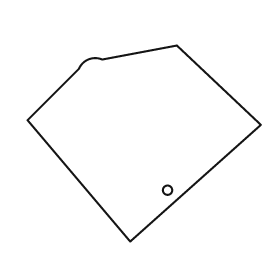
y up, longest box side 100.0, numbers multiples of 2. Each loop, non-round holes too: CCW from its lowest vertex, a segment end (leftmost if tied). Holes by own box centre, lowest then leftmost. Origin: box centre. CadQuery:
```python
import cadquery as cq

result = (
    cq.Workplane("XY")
    .moveTo(-6.0, -42.0)
    .lineTo(50.0, 8.0)
    .lineTo(14.0, 42.0)
    .lineTo(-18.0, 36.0)
    .threePointArc((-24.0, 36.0), (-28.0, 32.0))
    .lineTo(-50.0, 10.0)
    .close()
    .moveTo(10.0, -20.0)
    .circle(2.0)
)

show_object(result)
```